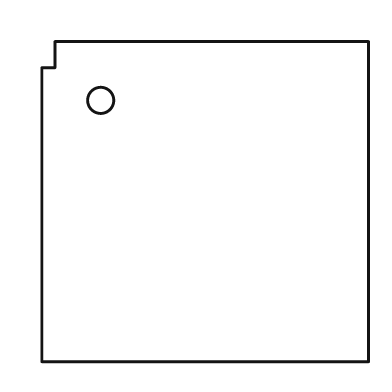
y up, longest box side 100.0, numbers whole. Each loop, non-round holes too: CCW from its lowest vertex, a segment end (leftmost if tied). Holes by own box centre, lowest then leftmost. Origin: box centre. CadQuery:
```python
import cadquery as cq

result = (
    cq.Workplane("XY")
    .moveTo(-50.0, -49.0)
    .lineTo(50.0, -49.0)
    .lineTo(50.0, 49.0)
    .lineTo(-46.0, 49.0)
    .lineTo(-46.0, 41.0)
    .lineTo(-50.0, 41.0)
    .close()
    .moveTo(-32.0, 31.0)
    .circle(4.0)
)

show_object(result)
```